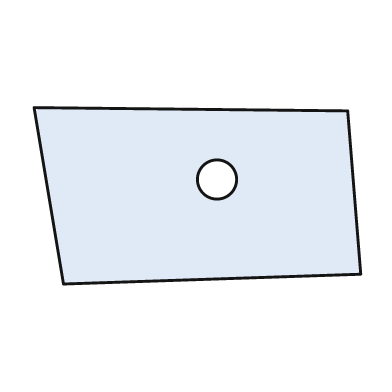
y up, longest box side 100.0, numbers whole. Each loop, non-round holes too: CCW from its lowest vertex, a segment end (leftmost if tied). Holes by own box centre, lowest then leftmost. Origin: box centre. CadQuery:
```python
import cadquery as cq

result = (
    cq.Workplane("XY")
    .moveTo(-41.0, -27.0)
    .lineTo(50.0, -24.0)
    .lineTo(46.0, 26.0)
    .lineTo(-50.0, 27.0)
    .close()
    .moveTo(6.0, 5.0)
    .circle(6.0)
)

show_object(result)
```